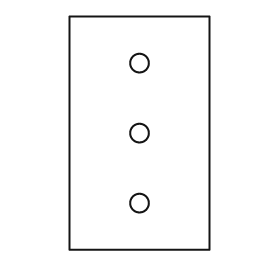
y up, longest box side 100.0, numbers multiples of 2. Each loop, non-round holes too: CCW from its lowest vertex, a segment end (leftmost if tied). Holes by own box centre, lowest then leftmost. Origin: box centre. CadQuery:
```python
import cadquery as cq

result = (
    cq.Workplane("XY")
    .moveTo(-30.0, -50.0)
    .lineTo(30.0, -50.0)
    .lineTo(30.0, 50.0)
    .lineTo(-30.0, 50.0)
    .close()
    .moveTo(0.0, -30.0)
    .circle(4.0)
    .moveTo(0.0, 0.0)
    .circle(4.0)
    .moveTo(0.0, 30.0)
    .circle(4.0)
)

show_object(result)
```